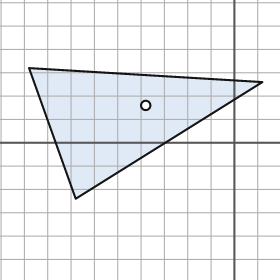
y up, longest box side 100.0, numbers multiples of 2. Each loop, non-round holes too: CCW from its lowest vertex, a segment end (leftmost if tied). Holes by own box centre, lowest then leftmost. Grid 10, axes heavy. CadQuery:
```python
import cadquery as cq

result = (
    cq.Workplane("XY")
    .moveTo(-68.0, -24.0)
    .lineTo(12.0, 26.0)
    .lineTo(-88.0, 32.0)
    .close()
    .moveTo(-38.0, 16.0)
    .circle(2.0)
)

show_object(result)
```